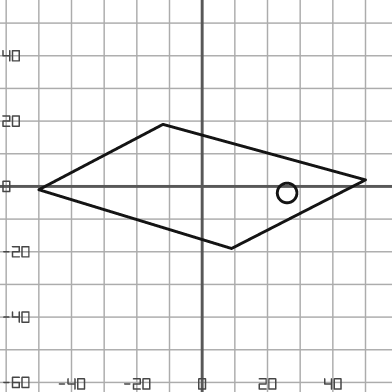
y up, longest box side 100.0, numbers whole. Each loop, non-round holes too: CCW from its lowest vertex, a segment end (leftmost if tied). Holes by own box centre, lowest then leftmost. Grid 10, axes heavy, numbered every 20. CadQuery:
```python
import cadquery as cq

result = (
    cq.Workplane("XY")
    .moveTo(9.0, -19.0)
    .lineTo(50.0, 2.0)
    .lineTo(-12.0, 19.0)
    .lineTo(-50.0, -1.0)
    .close()
    .moveTo(26.0, -2.0)
    .circle(3.0)
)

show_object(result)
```